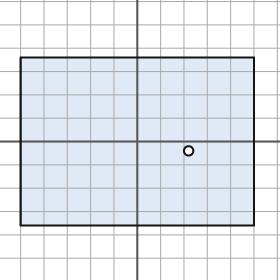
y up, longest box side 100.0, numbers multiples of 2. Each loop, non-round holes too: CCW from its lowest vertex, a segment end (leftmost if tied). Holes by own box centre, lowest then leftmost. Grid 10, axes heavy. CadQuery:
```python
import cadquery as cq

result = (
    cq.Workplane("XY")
    .moveTo(-50.0, -36.0)
    .lineTo(50.0, -36.0)
    .lineTo(50.0, 36.0)
    .lineTo(-50.0, 36.0)
    .close()
    .moveTo(22.0, -4.0)
    .circle(2.0)
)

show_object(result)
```